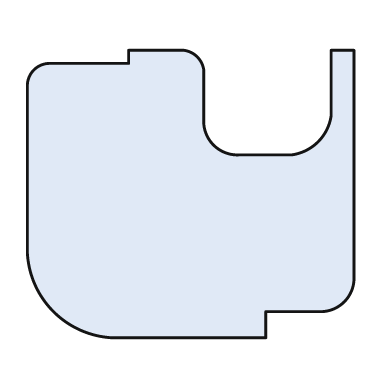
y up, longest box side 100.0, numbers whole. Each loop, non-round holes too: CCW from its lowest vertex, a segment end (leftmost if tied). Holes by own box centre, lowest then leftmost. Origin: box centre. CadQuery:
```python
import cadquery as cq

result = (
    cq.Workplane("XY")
    .moveTo(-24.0, -44.0)
    .lineTo(23.0, -44.0)
    .lineTo(23.0, -36.0)
    .lineTo(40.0, -36.0)
    .threePointArc((47.0, -33.0), (50.0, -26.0))
    .lineTo(50.0, 44.0)
    .lineTo(43.0, 44.0)
    .lineTo(43.0, 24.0)
    .threePointArc((39.0, 16.0), (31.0, 12.0))
    .lineTo(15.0, 12.0)
    .threePointArc((7.0, 15.0), (4.0, 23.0))
    .lineTo(4.0, 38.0)
    .threePointArc((2.0, 42.0), (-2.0, 44.0))
    .lineTo(-19.0, 44.0)
    .lineTo(-19.0, 40.0)
    .lineTo(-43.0, 40.0)
    .threePointArc((-48.0, 38.0), (-50.0, 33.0))
    .lineTo(-50.0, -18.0)
    .threePointArc((-42.0, -36.0), (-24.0, -44.0))
    .close()
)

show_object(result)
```